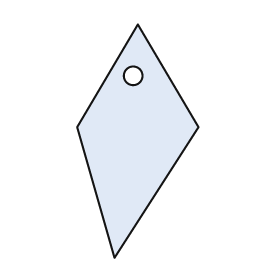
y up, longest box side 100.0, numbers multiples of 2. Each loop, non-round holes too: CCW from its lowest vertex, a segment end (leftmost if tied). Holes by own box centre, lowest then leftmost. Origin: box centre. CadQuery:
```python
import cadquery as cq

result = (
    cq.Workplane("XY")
    .moveTo(-10.0, -50.0)
    .lineTo(26.0, 6.0)
    .lineTo(0.0, 50.0)
    .lineTo(-26.0, 6.0)
    .close()
    .moveTo(-2.0, 28.0)
    .circle(4.0)
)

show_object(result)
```